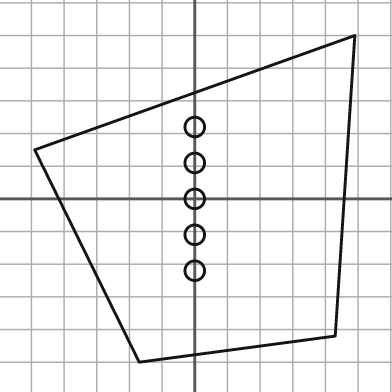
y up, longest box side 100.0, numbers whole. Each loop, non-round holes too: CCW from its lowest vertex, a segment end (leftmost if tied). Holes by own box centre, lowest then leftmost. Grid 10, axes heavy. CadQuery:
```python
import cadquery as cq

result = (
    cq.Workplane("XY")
    .moveTo(-17.0, -50.0)
    .lineTo(43.0, -42.0)
    .lineTo(49.0, 50.0)
    .lineTo(-49.0, 15.0)
    .close()
    .moveTo(0.0, -22.0)
    .circle(3.0)
    .moveTo(0.0, -11.0)
    .circle(3.0)
    .moveTo(0.0, 0.0)
    .circle(3.0)
    .moveTo(0.0, 11.0)
    .circle(3.0)
    .moveTo(0.0, 22.0)
    .circle(3.0)
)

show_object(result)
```